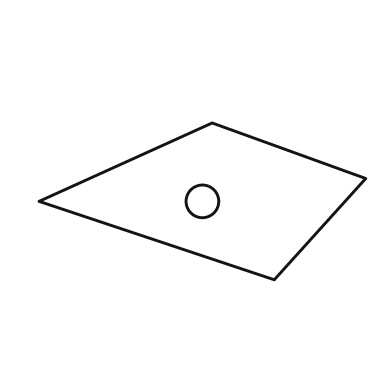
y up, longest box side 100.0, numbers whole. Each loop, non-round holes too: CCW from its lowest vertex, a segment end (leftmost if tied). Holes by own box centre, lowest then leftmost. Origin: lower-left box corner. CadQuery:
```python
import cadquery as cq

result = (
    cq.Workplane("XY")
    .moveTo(72.0, 0.0)
    .lineTo(100.0, 31.0)
    .lineTo(53.0, 48.0)
    .lineTo(0.0, 24.0)
    .close()
    .moveTo(50.0, 24.0)
    .circle(5.0)
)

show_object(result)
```